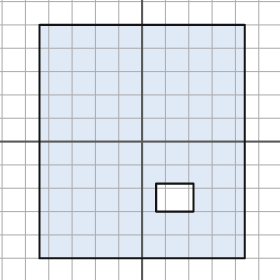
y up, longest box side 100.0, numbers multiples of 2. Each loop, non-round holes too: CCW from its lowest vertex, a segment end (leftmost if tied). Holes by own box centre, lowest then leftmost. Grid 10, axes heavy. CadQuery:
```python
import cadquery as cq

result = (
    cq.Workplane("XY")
    .moveTo(-44.0, -50.0)
    .lineTo(44.0, -50.0)
    .lineTo(44.0, 50.0)
    .lineTo(-44.0, 50.0)
    .close()
    .moveTo(6.0, -30.0)
    .lineTo(22.0, -30.0)
    .lineTo(22.0, -18.0)
    .lineTo(6.0, -18.0)
    .close()
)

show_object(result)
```